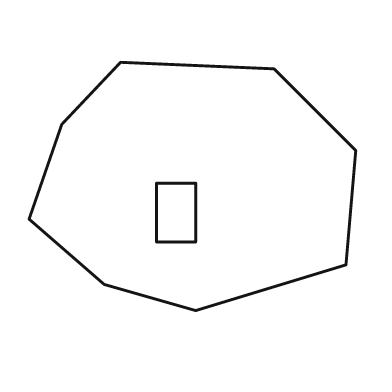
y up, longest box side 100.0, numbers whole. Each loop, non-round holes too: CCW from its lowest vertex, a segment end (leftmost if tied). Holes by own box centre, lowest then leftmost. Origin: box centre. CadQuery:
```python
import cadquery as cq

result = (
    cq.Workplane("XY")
    .moveTo(1.0, -38.0)
    .lineTo(47.0, -24.0)
    .lineTo(50.0, 11.0)
    .lineTo(25.0, 36.0)
    .lineTo(-22.0, 38.0)
    .lineTo(-40.0, 19.0)
    .lineTo(-50.0, -10.0)
    .lineTo(-27.0, -30.0)
    .close()
    .moveTo(-11.0, -17.0)
    .lineTo(1.0, -17.0)
    .lineTo(1.0, 1.0)
    .lineTo(-11.0, 1.0)
    .close()
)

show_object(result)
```